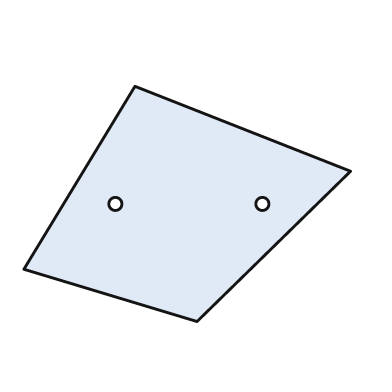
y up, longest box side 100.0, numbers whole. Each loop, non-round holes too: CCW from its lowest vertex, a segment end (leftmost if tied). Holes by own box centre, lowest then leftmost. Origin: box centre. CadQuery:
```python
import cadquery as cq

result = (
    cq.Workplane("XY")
    .moveTo(3.0, -36.0)
    .lineTo(50.0, 10.0)
    .lineTo(-16.0, 36.0)
    .lineTo(-50.0, -20.0)
    .close()
    .moveTo(-22.0, 0.0)
    .circle(2.0)
    .moveTo(23.0, 0.0)
    .circle(2.0)
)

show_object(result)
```